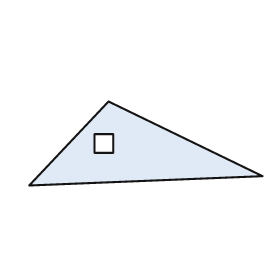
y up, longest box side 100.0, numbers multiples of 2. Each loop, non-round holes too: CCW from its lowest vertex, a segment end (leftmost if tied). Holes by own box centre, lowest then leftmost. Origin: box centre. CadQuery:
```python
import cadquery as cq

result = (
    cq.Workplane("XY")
    .moveTo(-50.0, -18.0)
    .lineTo(50.0, -14.0)
    .lineTo(-16.0, 18.0)
    .close()
    .moveTo(-22.0, -4.0)
    .lineTo(-14.0, -4.0)
    .lineTo(-14.0, 4.0)
    .lineTo(-22.0, 4.0)
    .close()
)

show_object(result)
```